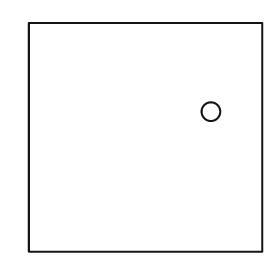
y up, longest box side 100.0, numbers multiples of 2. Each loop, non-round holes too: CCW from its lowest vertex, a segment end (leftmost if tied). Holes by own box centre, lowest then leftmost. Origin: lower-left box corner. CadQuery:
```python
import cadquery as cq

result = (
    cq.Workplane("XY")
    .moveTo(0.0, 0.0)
    .lineTo(100.0, 0.0)
    .lineTo(100.0, 98.0)
    .lineTo(0.0, 98.0)
    .close()
    .moveTo(78.0, 60.0)
    .circle(4.0)
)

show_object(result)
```